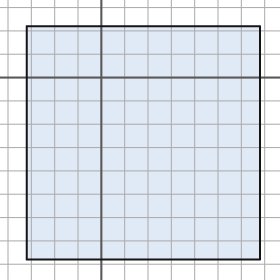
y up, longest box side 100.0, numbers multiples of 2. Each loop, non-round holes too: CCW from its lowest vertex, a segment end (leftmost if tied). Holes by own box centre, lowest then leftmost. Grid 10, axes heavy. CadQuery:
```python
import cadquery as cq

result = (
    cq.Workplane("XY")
    .moveTo(-32.0, -78.0)
    .lineTo(68.0, -78.0)
    .lineTo(68.0, 22.0)
    .lineTo(-32.0, 22.0)
    .close()
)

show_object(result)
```